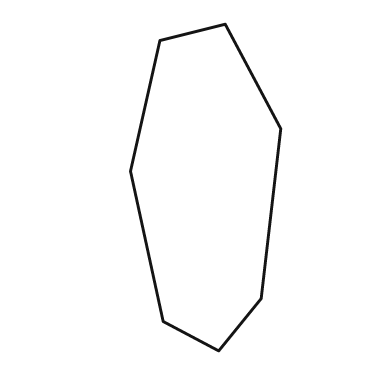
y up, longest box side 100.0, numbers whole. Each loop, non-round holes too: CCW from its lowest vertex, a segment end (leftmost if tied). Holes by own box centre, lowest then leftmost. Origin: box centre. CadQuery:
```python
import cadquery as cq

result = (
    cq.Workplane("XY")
    .moveTo(4.0, -50.0)
    .lineTo(17.0, -34.0)
    .lineTo(23.0, 18.0)
    .lineTo(6.0, 50.0)
    .lineTo(-14.0, 45.0)
    .lineTo(-23.0, 5.0)
    .lineTo(-13.0, -41.0)
    .close()
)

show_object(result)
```